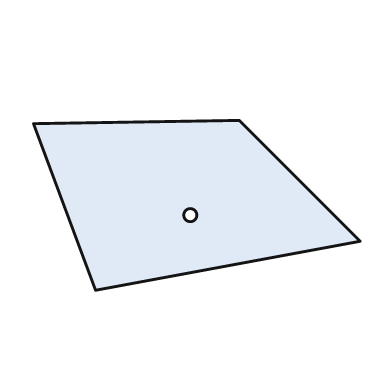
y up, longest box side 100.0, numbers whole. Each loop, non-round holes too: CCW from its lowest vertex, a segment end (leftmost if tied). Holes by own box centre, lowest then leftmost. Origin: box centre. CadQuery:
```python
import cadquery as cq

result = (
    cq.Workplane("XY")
    .moveTo(-31.0, -26.0)
    .lineTo(50.0, -11.0)
    .lineTo(13.0, 26.0)
    .lineTo(-50.0, 25.0)
    .close()
    .moveTo(-2.0, -3.0)
    .circle(2.0)
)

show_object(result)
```